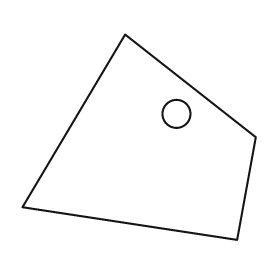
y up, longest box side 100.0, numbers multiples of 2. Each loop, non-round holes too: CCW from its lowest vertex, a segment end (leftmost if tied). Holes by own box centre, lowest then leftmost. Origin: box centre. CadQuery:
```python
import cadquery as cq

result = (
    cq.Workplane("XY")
    .moveTo(42.0, -44.0)
    .lineTo(50.0, 0.0)
    .lineTo(-6.0, 44.0)
    .lineTo(-50.0, -30.0)
    .close()
    .moveTo(16.0, 10.0)
    .circle(6.0)
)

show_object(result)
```